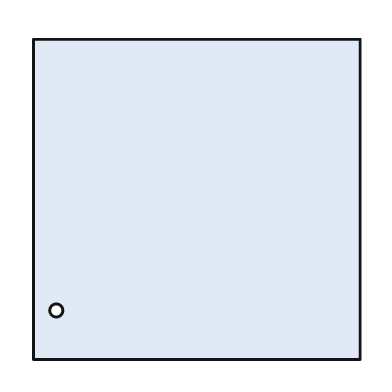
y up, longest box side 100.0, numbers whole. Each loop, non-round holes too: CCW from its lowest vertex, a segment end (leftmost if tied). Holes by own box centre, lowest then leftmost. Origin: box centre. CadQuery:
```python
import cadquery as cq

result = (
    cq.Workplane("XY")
    .moveTo(-50.0, -49.0)
    .lineTo(50.0, -49.0)
    .lineTo(50.0, 49.0)
    .lineTo(-50.0, 49.0)
    .close()
    .moveTo(-43.0, -34.0)
    .circle(2.0)
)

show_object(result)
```